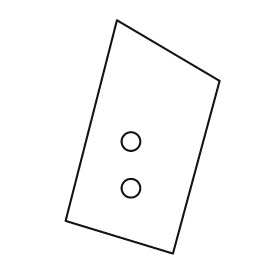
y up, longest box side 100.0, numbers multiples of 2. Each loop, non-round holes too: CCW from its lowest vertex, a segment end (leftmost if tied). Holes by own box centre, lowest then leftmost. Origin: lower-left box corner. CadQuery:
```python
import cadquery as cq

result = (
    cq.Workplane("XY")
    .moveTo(46.0, 0.0)
    .lineTo(66.0, 74.0)
    .lineTo(22.0, 100.0)
    .lineTo(0.0, 14.0)
    .close()
    .moveTo(28.0, 28.0)
    .circle(4.0)
    .moveTo(28.0, 48.0)
    .circle(4.0)
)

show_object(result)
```